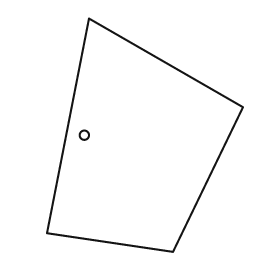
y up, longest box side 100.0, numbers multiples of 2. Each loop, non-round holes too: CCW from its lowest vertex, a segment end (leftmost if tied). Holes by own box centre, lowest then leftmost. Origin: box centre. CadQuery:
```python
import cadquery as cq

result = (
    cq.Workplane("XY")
    .moveTo(12.0, -50.0)
    .lineTo(42.0, 12.0)
    .lineTo(-24.0, 50.0)
    .lineTo(-42.0, -42.0)
    .close()
    .moveTo(-26.0, 0.0)
    .circle(2.0)
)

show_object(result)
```